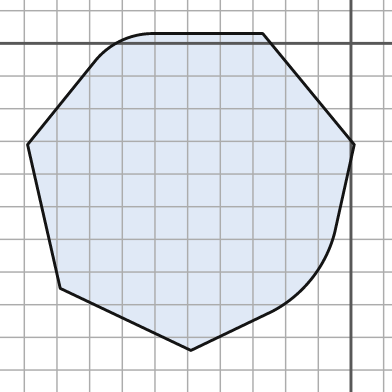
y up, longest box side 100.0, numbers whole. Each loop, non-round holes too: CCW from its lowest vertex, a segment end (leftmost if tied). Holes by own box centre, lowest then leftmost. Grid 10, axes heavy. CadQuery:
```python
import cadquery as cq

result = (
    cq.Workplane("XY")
    .moveTo(-49.0, -94.0)
    .lineTo(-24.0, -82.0)
    .threePointArc((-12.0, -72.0), (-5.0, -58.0))
    .lineTo(1.0, -31.0)
    .lineTo(-27.0, 3.0)
    .lineTo(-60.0, 3.0)
    .threePointArc((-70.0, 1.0), (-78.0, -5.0))
    .lineTo(-99.0, -31.0)
    .lineTo(-89.0, -75.0)
    .close()
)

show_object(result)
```